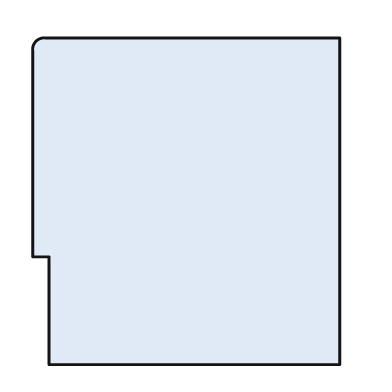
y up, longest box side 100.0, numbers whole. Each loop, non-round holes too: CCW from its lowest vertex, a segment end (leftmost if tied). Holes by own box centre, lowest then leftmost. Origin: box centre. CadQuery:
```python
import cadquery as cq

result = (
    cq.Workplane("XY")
    .moveTo(-42.0, -50.0)
    .lineTo(47.0, -50.0)
    .lineTo(47.0, 50.0)
    .lineTo(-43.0, 50.0)
    .threePointArc((-46.0, 49.0), (-47.0, 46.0))
    .lineTo(-47.0, -17.0)
    .lineTo(-42.0, -17.0)
    .close()
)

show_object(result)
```